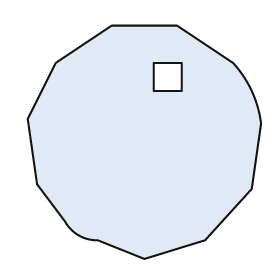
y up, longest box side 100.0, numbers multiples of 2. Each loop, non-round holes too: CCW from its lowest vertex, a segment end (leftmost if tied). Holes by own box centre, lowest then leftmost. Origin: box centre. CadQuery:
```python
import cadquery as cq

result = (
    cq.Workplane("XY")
    .moveTo(0.0, -50.0)
    .lineTo(26.0, -42.0)
    .lineTo(46.0, -20.0)
    .lineTo(50.0, 8.0)
    .threePointArc((46.0, 22.0), (38.0, 34.0))
    .lineTo(14.0, 50.0)
    .lineTo(-14.0, 50.0)
    .lineTo(-38.0, 34.0)
    .lineTo(-50.0, 10.0)
    .lineTo(-46.0, -18.0)
    .lineTo(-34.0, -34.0)
    .threePointArc((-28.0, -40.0), (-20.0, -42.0))
    .close()
    .moveTo(4.0, 22.0)
    .lineTo(16.0, 22.0)
    .lineTo(16.0, 34.0)
    .lineTo(4.0, 34.0)
    .close()
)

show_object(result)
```